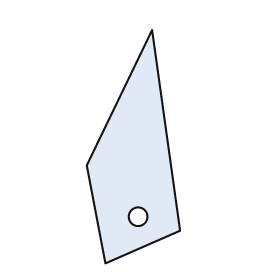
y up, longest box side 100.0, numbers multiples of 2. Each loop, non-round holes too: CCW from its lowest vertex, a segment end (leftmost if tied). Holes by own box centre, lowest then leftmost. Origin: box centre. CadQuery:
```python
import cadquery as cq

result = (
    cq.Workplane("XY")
    .moveTo(-12.0, -50.0)
    .lineTo(20.0, -36.0)
    .lineTo(8.0, 50.0)
    .lineTo(-20.0, -8.0)
    .close()
    .moveTo(2.0, -30.0)
    .circle(4.0)
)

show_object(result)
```